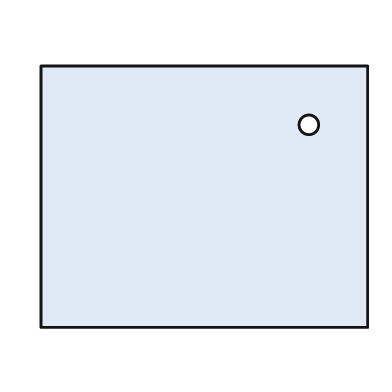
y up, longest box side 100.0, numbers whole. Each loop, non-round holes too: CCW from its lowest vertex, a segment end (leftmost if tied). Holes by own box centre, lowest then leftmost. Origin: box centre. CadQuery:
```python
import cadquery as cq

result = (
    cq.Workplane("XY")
    .moveTo(-50.0, -40.0)
    .lineTo(50.0, -40.0)
    .lineTo(50.0, 40.0)
    .lineTo(-50.0, 40.0)
    .close()
    .moveTo(32.0, 22.0)
    .circle(3.0)
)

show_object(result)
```